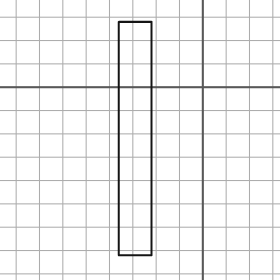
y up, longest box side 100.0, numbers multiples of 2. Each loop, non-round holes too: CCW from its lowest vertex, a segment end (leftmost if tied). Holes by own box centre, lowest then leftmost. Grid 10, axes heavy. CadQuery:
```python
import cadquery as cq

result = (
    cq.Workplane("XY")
    .moveTo(-36.0, -72.0)
    .lineTo(-22.0, -72.0)
    .lineTo(-22.0, 28.0)
    .lineTo(-36.0, 28.0)
    .close()
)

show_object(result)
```